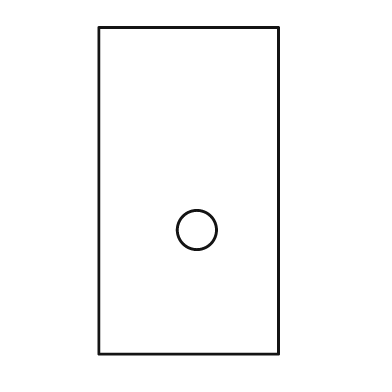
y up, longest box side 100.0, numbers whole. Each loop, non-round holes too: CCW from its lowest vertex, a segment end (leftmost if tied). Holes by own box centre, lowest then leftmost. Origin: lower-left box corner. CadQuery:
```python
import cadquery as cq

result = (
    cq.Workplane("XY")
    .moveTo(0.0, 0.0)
    .lineTo(55.0, 0.0)
    .lineTo(55.0, 100.0)
    .lineTo(0.0, 100.0)
    .close()
    .moveTo(30.0, 38.0)
    .circle(6.0)
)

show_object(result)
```